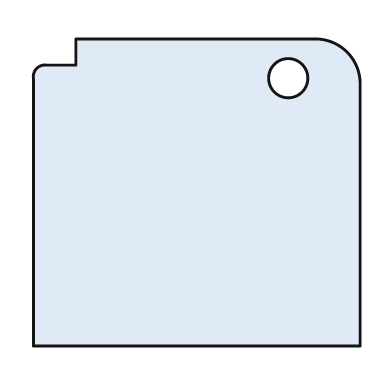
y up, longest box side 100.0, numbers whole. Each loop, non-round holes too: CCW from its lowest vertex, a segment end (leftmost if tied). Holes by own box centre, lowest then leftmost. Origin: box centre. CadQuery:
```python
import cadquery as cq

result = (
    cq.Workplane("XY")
    .moveTo(-50.0, -47.0)
    .lineTo(50.0, -47.0)
    .lineTo(50.0, 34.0)
    .threePointArc((46.0, 43.0), (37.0, 47.0))
    .lineTo(-37.0, 47.0)
    .lineTo(-37.0, 39.0)
    .lineTo(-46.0, 39.0)
    .threePointArc((-49.0, 38.0), (-50.0, 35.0))
    .close()
    .moveTo(28.0, 35.0)
    .circle(6.0)
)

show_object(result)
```